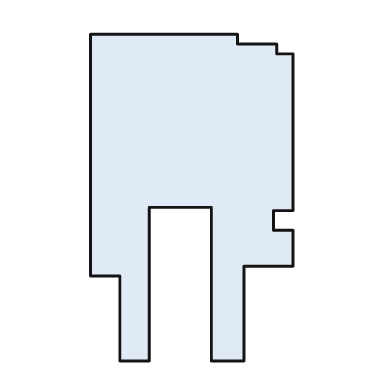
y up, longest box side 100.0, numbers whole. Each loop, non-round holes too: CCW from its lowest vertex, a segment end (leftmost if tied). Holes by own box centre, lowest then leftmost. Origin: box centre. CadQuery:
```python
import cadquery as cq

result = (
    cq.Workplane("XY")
    .moveTo(-22.0, -50.0)
    .lineTo(-13.0, -50.0)
    .lineTo(-13.0, -3.0)
    .lineTo(6.0, -3.0)
    .lineTo(6.0, -50.0)
    .lineTo(16.0, -50.0)
    .lineTo(16.0, -21.0)
    .lineTo(31.0, -21.0)
    .lineTo(31.0, -10.0)
    .lineTo(25.0, -10.0)
    .lineTo(25.0, -4.0)
    .lineTo(31.0, -4.0)
    .lineTo(31.0, 44.0)
    .lineTo(26.0, 44.0)
    .lineTo(26.0, 47.0)
    .lineTo(14.0, 47.0)
    .lineTo(14.0, 50.0)
    .lineTo(-31.0, 50.0)
    .lineTo(-31.0, -24.0)
    .lineTo(-22.0, -24.0)
    .close()
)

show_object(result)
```